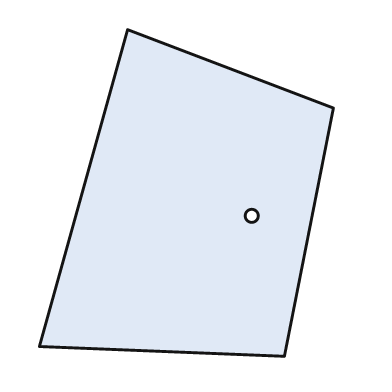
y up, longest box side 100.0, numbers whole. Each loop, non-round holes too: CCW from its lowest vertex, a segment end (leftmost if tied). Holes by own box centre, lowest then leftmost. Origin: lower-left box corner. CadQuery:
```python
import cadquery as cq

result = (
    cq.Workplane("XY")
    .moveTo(75.0, 0.0)
    .lineTo(90.0, 76.0)
    .lineTo(27.0, 100.0)
    .lineTo(0.0, 3.0)
    .close()
    .moveTo(65.0, 43.0)
    .circle(2.0)
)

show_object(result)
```